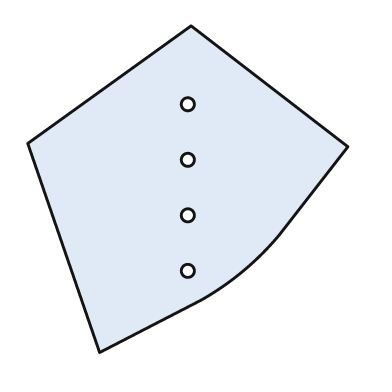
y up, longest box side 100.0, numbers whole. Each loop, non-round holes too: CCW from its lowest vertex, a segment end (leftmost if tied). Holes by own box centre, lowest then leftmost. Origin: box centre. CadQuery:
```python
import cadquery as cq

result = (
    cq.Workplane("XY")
    .moveTo(-27.0, -50.0)
    .lineTo(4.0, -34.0)
    .threePointArc((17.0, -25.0), (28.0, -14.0))
    .lineTo(49.0, 13.0)
    .lineTo(1.0, 50.0)
    .lineTo(-49.0, 14.0)
    .close()
    .moveTo(0.0, -25.0)
    .circle(2.0)
    .moveTo(0.0, -8.0)
    .circle(2.0)
    .moveTo(0.0, 9.0)
    .circle(2.0)
    .moveTo(0.0, 26.0)
    .circle(2.0)
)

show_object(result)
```